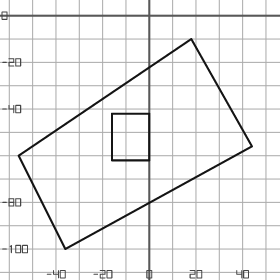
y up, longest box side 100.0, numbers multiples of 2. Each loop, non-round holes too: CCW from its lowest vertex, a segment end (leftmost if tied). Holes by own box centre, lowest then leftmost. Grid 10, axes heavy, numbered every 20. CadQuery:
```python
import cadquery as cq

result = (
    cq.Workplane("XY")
    .moveTo(-36.0, -100.0)
    .lineTo(44.0, -56.0)
    .lineTo(18.0, -10.0)
    .lineTo(-56.0, -60.0)
    .close()
    .moveTo(-16.0, -62.0)
    .lineTo(0.0, -62.0)
    .lineTo(0.0, -42.0)
    .lineTo(-16.0, -42.0)
    .close()
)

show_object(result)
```